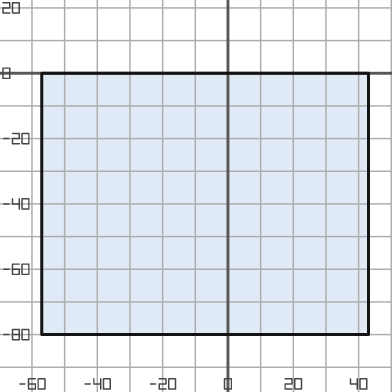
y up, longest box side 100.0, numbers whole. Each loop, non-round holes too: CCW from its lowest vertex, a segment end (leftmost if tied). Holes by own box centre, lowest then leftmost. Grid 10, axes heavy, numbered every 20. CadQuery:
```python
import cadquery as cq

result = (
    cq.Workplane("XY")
    .moveTo(-57.0, -80.0)
    .lineTo(43.0, -80.0)
    .lineTo(43.0, 0.0)
    .lineTo(-57.0, 0.0)
    .close()
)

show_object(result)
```